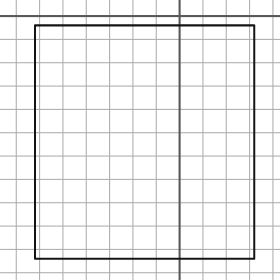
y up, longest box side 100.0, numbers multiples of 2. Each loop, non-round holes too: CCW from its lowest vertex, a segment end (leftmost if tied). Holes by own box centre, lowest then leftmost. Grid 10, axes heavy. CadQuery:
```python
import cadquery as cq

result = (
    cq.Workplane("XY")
    .moveTo(-62.0, -104.0)
    .lineTo(32.0, -104.0)
    .lineTo(32.0, -4.0)
    .lineTo(-62.0, -4.0)
    .close()
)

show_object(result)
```